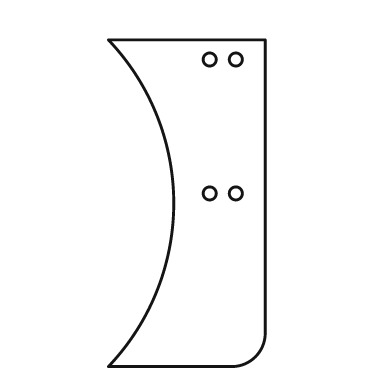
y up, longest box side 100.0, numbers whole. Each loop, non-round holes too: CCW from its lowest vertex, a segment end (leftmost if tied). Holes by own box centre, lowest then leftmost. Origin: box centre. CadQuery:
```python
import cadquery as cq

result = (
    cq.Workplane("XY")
    .moveTo(-24.0, -50.0)
    .lineTo(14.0, -50.0)
    .threePointArc((21.0, -47.0), (24.0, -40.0))
    .lineTo(24.0, 50.0)
    .lineTo(-24.0, 50.0)
    .threePointArc((-4.0, 0.0), (-24.0, -50.0))
    .close()
    .moveTo(7.0, 3.0)
    .circle(2.0)
    .moveTo(15.0, 3.0)
    .circle(2.0)
    .moveTo(7.0, 44.0)
    .circle(2.0)
    .moveTo(15.0, 44.0)
    .circle(2.0)
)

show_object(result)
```